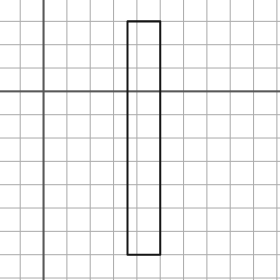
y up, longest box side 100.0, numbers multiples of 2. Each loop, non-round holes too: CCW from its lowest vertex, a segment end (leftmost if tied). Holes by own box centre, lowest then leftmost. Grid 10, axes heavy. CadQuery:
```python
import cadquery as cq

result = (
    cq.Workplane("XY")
    .moveTo(36.0, -70.0)
    .lineTo(50.0, -70.0)
    .lineTo(50.0, 30.0)
    .lineTo(36.0, 30.0)
    .close()
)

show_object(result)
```